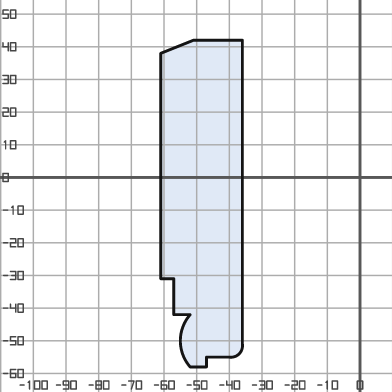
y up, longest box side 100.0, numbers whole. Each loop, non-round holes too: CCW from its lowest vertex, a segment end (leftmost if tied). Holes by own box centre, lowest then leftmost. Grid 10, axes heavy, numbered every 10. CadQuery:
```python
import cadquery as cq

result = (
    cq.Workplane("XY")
    .moveTo(-52.0, -58.0)
    .lineTo(-47.0, -58.0)
    .lineTo(-47.0, -55.0)
    .lineTo(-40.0, -55.0)
    .threePointArc((-37.0, -54.0), (-36.0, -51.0))
    .lineTo(-36.0, 42.0)
    .lineTo(-51.0, 42.0)
    .lineTo(-61.0, 38.0)
    .lineTo(-61.0, -31.0)
    .lineTo(-57.0, -31.0)
    .lineTo(-57.0, -42.0)
    .lineTo(-52.0, -42.0)
    .threePointArc((-55.0, -50.0), (-52.0, -58.0))
    .close()
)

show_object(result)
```